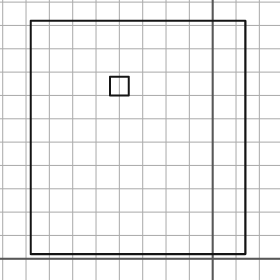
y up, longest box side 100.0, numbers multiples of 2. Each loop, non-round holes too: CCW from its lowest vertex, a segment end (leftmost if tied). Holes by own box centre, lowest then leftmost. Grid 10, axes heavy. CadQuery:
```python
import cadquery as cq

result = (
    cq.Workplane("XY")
    .moveTo(-78.0, 2.0)
    .lineTo(14.0, 2.0)
    .lineTo(14.0, 102.0)
    .lineTo(-78.0, 102.0)
    .close()
    .moveTo(-44.0, 70.0)
    .lineTo(-36.0, 70.0)
    .lineTo(-36.0, 78.0)
    .lineTo(-44.0, 78.0)
    .close()
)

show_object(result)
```